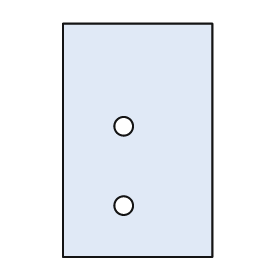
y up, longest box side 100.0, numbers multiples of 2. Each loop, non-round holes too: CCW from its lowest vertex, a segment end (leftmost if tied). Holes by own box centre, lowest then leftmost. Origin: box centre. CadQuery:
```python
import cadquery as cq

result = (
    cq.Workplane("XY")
    .moveTo(-32.0, -50.0)
    .lineTo(32.0, -50.0)
    .lineTo(32.0, 50.0)
    .lineTo(-32.0, 50.0)
    .close()
    .moveTo(-6.0, -28.0)
    .circle(4.0)
    .moveTo(-6.0, 6.0)
    .circle(4.0)
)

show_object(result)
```